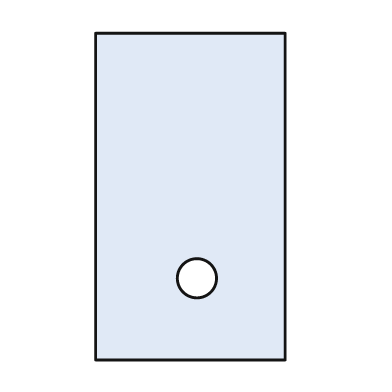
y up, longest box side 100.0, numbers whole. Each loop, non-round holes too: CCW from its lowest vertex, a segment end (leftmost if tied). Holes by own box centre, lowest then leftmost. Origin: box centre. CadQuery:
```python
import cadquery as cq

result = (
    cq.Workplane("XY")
    .moveTo(-29.0, -50.0)
    .lineTo(29.0, -50.0)
    .lineTo(29.0, 50.0)
    .lineTo(-29.0, 50.0)
    .close()
    .moveTo(2.0, -25.0)
    .circle(6.0)
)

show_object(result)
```